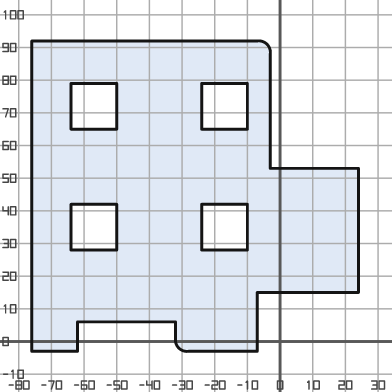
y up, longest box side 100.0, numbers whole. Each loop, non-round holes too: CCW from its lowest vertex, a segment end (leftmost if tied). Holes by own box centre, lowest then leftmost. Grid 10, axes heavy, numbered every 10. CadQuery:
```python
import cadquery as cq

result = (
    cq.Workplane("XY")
    .moveTo(-76.0, -3.0)
    .lineTo(-62.0, -3.0)
    .lineTo(-62.0, 6.0)
    .lineTo(-32.0, 6.0)
    .lineTo(-32.0, 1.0)
    .threePointArc((-31.0, -2.0), (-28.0, -3.0))
    .lineTo(-7.0, -3.0)
    .lineTo(-7.0, 15.0)
    .lineTo(24.0, 15.0)
    .lineTo(24.0, 53.0)
    .lineTo(-3.0, 53.0)
    .lineTo(-3.0, 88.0)
    .threePointArc((-4.0, 91.0), (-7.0, 92.0))
    .lineTo(-76.0, 92.0)
    .close()
    .moveTo(-64.0, 28.0)
    .lineTo(-50.0, 28.0)
    .lineTo(-50.0, 42.0)
    .lineTo(-64.0, 42.0)
    .close()
    .moveTo(-24.0, 28.0)
    .lineTo(-10.0, 28.0)
    .lineTo(-10.0, 42.0)
    .lineTo(-24.0, 42.0)
    .close()
    .moveTo(-64.0, 65.0)
    .lineTo(-50.0, 65.0)
    .lineTo(-50.0, 79.0)
    .lineTo(-64.0, 79.0)
    .close()
    .moveTo(-24.0, 65.0)
    .lineTo(-10.0, 65.0)
    .lineTo(-10.0, 79.0)
    .lineTo(-24.0, 79.0)
    .close()
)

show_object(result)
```